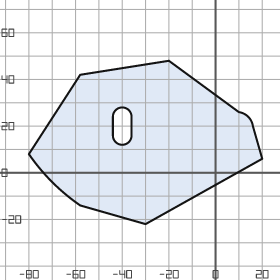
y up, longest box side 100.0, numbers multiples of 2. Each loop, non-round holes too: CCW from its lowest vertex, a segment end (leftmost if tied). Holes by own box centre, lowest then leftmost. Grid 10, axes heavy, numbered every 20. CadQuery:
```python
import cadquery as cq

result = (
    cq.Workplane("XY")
    .moveTo(-30.0, -22.0)
    .lineTo(20.0, 6.0)
    .lineTo(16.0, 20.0)
    .threePointArc((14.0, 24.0), (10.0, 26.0))
    .lineTo(-20.0, 48.0)
    .lineTo(-58.0, 42.0)
    .lineTo(-80.0, 8.0)
    .threePointArc((-70.0, -4.0), (-58.0, -14.0))
    .close()
    .moveTo(-44.0, 16.0)
    .threePointArc((-40.0, 12.0), (-36.0, 16.0))
    .lineTo(-36.0, 24.0)
    .threePointArc((-40.0, 28.0), (-44.0, 24.0))
    .close()
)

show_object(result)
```